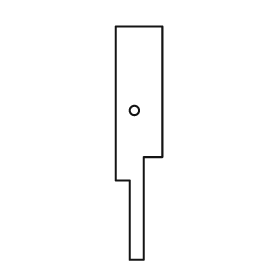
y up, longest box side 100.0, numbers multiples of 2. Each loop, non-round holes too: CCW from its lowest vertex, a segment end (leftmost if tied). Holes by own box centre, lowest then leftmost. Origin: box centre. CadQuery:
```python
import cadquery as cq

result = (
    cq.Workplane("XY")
    .moveTo(-4.0, -50.0)
    .lineTo(2.0, -50.0)
    .lineTo(2.0, -6.0)
    .lineTo(10.0, -6.0)
    .lineTo(10.0, 50.0)
    .lineTo(-10.0, 50.0)
    .lineTo(-10.0, -16.0)
    .lineTo(-4.0, -16.0)
    .close()
    .moveTo(-2.0, 14.0)
    .circle(2.0)
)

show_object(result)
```